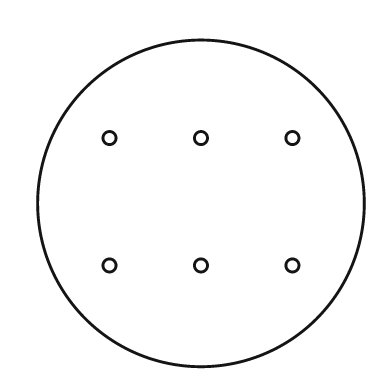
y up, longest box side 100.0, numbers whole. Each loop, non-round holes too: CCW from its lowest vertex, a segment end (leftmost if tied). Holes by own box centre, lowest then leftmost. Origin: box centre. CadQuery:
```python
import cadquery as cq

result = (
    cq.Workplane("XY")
    .moveTo(0.0, 0.0)
    .circle(50.0)
    .moveTo(-28.0, -19.0)
    .circle(2.0)
    .moveTo(0.0, -19.0)
    .circle(2.0)
    .moveTo(28.0, -19.0)
    .circle(2.0)
    .moveTo(-28.0, 20.0)
    .circle(2.0)
    .moveTo(0.0, 20.0)
    .circle(2.0)
    .moveTo(28.0, 20.0)
    .circle(2.0)
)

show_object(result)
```